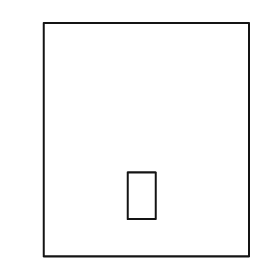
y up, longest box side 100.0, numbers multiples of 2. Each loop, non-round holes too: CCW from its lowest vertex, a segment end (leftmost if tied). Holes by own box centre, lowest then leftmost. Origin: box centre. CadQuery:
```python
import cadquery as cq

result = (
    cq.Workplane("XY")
    .moveTo(-44.0, -50.0)
    .lineTo(44.0, -50.0)
    .lineTo(44.0, 50.0)
    .lineTo(-44.0, 50.0)
    .close()
    .moveTo(-8.0, -34.0)
    .lineTo(4.0, -34.0)
    .lineTo(4.0, -14.0)
    .lineTo(-8.0, -14.0)
    .close()
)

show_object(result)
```